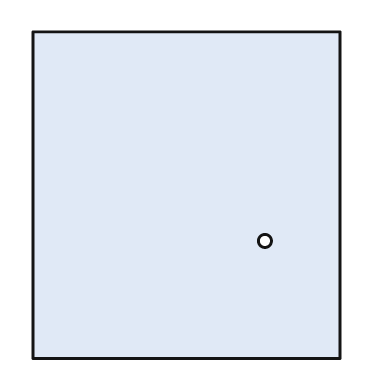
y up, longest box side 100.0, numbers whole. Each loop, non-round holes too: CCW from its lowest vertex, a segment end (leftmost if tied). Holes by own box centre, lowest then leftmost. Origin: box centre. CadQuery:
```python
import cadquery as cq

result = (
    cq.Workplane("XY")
    .moveTo(-47.0, -50.0)
    .lineTo(47.0, -50.0)
    .lineTo(47.0, 50.0)
    .lineTo(-47.0, 50.0)
    .close()
    .moveTo(24.0, -14.0)
    .circle(2.0)
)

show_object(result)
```